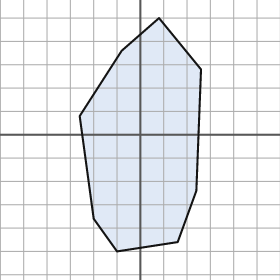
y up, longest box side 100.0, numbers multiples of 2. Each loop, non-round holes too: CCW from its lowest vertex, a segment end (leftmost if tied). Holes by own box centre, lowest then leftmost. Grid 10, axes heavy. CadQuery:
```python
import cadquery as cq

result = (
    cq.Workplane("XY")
    .moveTo(-10.0, -50.0)
    .lineTo(16.0, -46.0)
    .lineTo(24.0, -24.0)
    .lineTo(26.0, 28.0)
    .lineTo(8.0, 50.0)
    .lineTo(-8.0, 36.0)
    .lineTo(-26.0, 8.0)
    .lineTo(-20.0, -36.0)
    .close()
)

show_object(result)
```